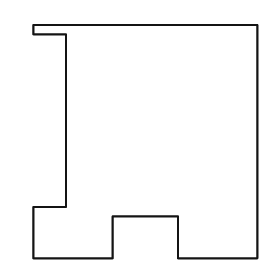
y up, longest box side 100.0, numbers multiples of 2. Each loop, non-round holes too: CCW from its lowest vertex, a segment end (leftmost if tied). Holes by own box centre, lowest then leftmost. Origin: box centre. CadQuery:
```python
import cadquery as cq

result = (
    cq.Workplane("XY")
    .moveTo(-48.0, -50.0)
    .lineTo(-14.0, -50.0)
    .lineTo(-14.0, -32.0)
    .lineTo(14.0, -32.0)
    .lineTo(14.0, -50.0)
    .lineTo(48.0, -50.0)
    .lineTo(48.0, 50.0)
    .lineTo(-48.0, 50.0)
    .lineTo(-48.0, 46.0)
    .lineTo(-34.0, 46.0)
    .lineTo(-34.0, -28.0)
    .lineTo(-48.0, -28.0)
    .close()
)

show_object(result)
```